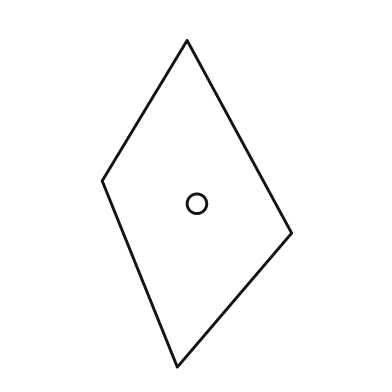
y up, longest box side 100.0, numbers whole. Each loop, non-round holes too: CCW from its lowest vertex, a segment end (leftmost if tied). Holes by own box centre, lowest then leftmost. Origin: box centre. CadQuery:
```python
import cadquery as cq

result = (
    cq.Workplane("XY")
    .moveTo(-6.0, -50.0)
    .lineTo(29.0, -9.0)
    .lineTo(-3.0, 50.0)
    .lineTo(-29.0, 7.0)
    .close()
    .moveTo(0.0, 0.0)
    .circle(3.0)
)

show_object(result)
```